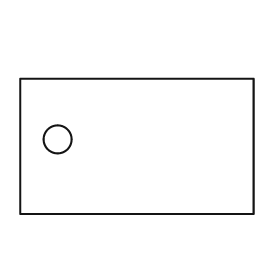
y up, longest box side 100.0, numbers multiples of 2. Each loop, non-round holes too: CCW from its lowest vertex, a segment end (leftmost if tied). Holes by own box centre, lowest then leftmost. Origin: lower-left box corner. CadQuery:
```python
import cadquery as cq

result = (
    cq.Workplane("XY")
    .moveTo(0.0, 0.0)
    .lineTo(100.0, 0.0)
    .lineTo(100.0, 58.0)
    .lineTo(0.0, 58.0)
    .close()
    .moveTo(16.0, 32.0)
    .circle(6.0)
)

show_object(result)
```